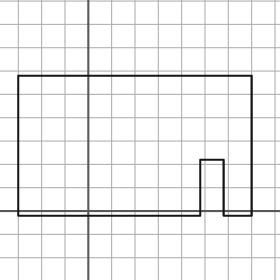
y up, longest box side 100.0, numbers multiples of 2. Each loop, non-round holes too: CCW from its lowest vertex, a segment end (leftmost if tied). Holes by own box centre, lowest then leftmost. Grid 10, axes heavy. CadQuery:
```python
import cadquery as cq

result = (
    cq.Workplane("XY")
    .moveTo(-30.0, -2.0)
    .lineTo(48.0, -2.0)
    .lineTo(48.0, 22.0)
    .lineTo(58.0, 22.0)
    .lineTo(58.0, -2.0)
    .lineTo(70.0, -2.0)
    .lineTo(70.0, 58.0)
    .lineTo(-30.0, 58.0)
    .close()
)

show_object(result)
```